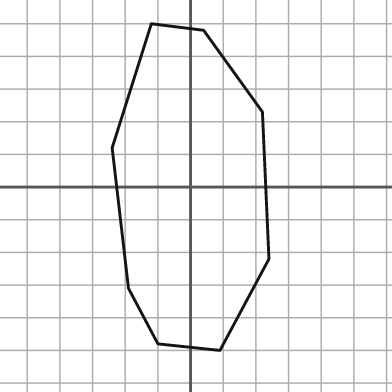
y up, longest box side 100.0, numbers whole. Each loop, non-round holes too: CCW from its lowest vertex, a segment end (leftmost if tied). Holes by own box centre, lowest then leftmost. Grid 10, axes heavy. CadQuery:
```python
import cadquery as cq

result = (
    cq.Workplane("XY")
    .moveTo(9.0, -50.0)
    .lineTo(24.0, -22.0)
    .lineTo(22.0, 23.0)
    .lineTo(4.0, 48.0)
    .lineTo(-12.0, 50.0)
    .lineTo(-24.0, 12.0)
    .lineTo(-19.0, -31.0)
    .lineTo(-10.0, -48.0)
    .close()
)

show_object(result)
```